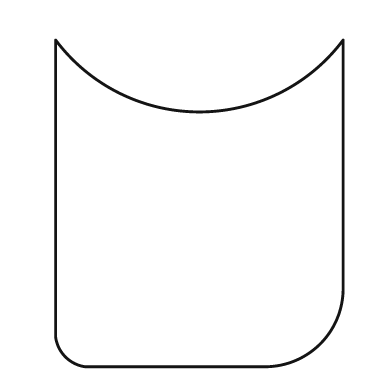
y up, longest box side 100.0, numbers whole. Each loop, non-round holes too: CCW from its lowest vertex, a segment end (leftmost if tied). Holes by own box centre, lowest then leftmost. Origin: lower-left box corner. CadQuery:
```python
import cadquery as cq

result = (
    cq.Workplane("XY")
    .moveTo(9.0, 0.0)
    .lineTo(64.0, 0.0)
    .threePointArc((81.0, 7.0), (88.0, 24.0))
    .lineTo(88.0, 100.0)
    .threePointArc((44.0, 78.0), (0.0, 100.0))
    .lineTo(0.0, 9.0)
    .threePointArc((3.0, 3.0), (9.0, 0.0))
    .close()
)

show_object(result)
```